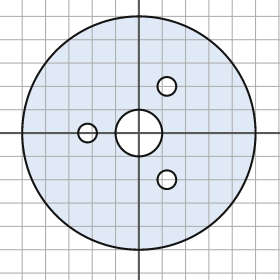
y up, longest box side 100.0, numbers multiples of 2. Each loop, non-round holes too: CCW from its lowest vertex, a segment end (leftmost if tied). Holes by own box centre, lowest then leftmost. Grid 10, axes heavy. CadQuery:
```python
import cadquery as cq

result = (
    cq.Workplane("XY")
    .moveTo(0.0, 0.0)
    .circle(50.0)
    .moveTo(12.0, -20.0)
    .circle(4.0)
    .moveTo(-22.0, 0.0)
    .circle(4.0)
    .moveTo(0.0, 0.0)
    .circle(10.0)
    .moveTo(12.0, 20.0)
    .circle(4.0)
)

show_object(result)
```